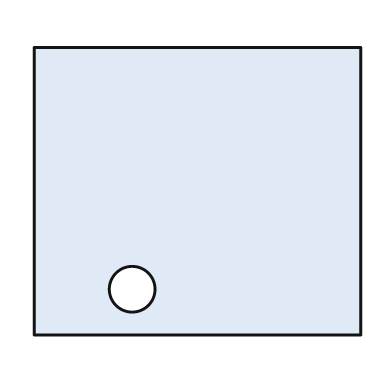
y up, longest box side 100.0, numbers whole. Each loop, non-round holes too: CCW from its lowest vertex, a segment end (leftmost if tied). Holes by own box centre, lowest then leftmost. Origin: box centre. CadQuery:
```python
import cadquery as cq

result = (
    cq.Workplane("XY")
    .moveTo(-50.0, -44.0)
    .lineTo(50.0, -44.0)
    .lineTo(50.0, 44.0)
    .lineTo(-50.0, 44.0)
    .close()
    .moveTo(-20.0, -30.0)
    .circle(7.0)
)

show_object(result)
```